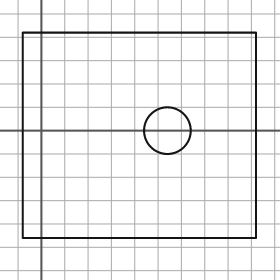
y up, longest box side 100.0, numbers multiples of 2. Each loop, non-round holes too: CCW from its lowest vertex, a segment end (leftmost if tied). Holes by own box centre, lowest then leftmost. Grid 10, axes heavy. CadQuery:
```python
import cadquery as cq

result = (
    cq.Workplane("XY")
    .moveTo(-8.0, -46.0)
    .lineTo(92.0, -46.0)
    .lineTo(92.0, 42.0)
    .lineTo(-8.0, 42.0)
    .close()
    .moveTo(54.0, 0.0)
    .circle(10.0)
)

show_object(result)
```